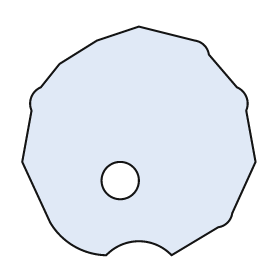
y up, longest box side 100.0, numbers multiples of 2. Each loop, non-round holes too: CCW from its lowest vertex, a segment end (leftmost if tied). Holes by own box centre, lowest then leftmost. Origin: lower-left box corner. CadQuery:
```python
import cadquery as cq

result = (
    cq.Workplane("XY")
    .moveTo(36.0, 0.0)
    .threePointArc((50.0, 6.0), (64.0, 0.0))
    .lineTo(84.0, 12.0)
    .threePointArc((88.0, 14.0), (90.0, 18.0))
    .lineTo(100.0, 40.0)
    .lineTo(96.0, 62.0)
    .threePointArc((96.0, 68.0), (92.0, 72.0))
    .lineTo(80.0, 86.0)
    .threePointArc((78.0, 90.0), (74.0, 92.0))
    .lineTo(50.0, 98.0)
    .lineTo(32.0, 92.0)
    .lineTo(16.0, 82.0)
    .lineTo(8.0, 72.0)
    .threePointArc((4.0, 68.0), (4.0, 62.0))
    .lineTo(0.0, 40.0)
    .lineTo(12.0, 14.0)
    .threePointArc((22.0, 4.0), (36.0, 0.0))
    .close()
    .moveTo(42.0, 32.0)
    .circle(8.0)
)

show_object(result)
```